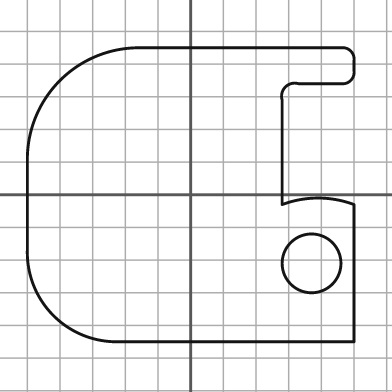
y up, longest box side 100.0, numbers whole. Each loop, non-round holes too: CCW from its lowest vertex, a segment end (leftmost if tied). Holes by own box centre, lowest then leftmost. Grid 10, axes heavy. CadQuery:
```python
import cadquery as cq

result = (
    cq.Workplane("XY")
    .moveTo(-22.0, -45.0)
    .lineTo(50.0, -45.0)
    .lineTo(50.0, -3.0)
    .threePointArc((39.0, -1.0), (28.0, -3.0))
    .lineTo(28.0, 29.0)
    .threePointArc((29.0, 33.0), (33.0, 34.0))
    .lineTo(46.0, 34.0)
    .threePointArc((49.0, 35.0), (50.0, 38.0))
    .lineTo(50.0, 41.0)
    .threePointArc((49.0, 44.0), (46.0, 45.0))
    .lineTo(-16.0, 45.0)
    .threePointArc((-40.0, 35.0), (-50.0, 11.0))
    .lineTo(-50.0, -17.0)
    .threePointArc((-42.0, -37.0), (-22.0, -45.0))
    .close()
    .moveTo(37.0, -21.0)
    .circle(9.0)
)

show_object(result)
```